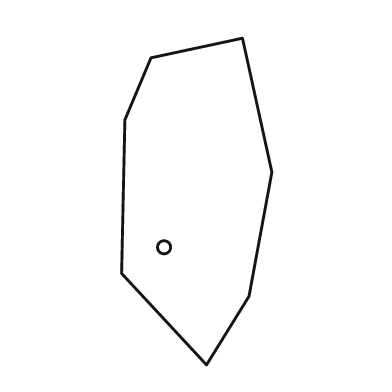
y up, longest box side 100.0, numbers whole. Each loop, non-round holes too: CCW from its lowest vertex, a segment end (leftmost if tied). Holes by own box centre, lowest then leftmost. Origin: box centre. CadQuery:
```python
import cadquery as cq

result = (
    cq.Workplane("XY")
    .moveTo(3.0, -50.0)
    .lineTo(16.0, -29.0)
    .lineTo(23.0, 9.0)
    .lineTo(14.0, 50.0)
    .lineTo(-14.0, 44.0)
    .lineTo(-22.0, 25.0)
    .lineTo(-23.0, -22.0)
    .close()
    .moveTo(-10.0, -14.0)
    .circle(2.0)
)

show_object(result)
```